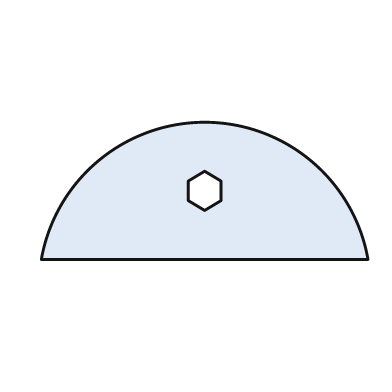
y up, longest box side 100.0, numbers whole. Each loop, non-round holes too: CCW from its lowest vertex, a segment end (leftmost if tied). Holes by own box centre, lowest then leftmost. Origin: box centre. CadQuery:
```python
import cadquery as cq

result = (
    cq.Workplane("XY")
    .moveTo(-50.0, -21.0)
    .lineTo(50.0, -21.0)
    .threePointArc((0.0, 21.0), (-50.0, -21.0))
    .close()
    .moveTo(0.0, -6.0)
    .lineTo(5.0, -3.0)
    .lineTo(5.0, 3.0)
    .lineTo(0.0, 6.0)
    .lineTo(-5.0, 3.0)
    .lineTo(-5.0, -3.0)
    .close()
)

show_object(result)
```